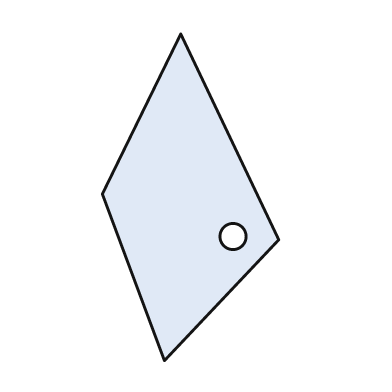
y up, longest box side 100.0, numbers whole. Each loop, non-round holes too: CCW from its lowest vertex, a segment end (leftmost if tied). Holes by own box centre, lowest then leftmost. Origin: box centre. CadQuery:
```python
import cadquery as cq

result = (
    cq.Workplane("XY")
    .moveTo(-8.0, -50.0)
    .lineTo(27.0, -13.0)
    .lineTo(-3.0, 50.0)
    .lineTo(-27.0, 1.0)
    .close()
    .moveTo(13.0, -12.0)
    .circle(4.0)
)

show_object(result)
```